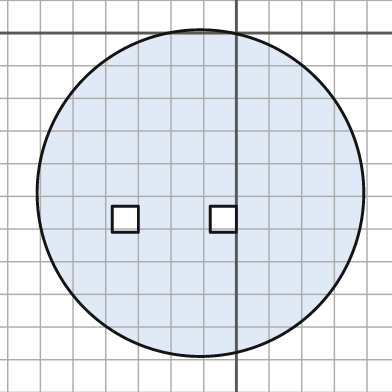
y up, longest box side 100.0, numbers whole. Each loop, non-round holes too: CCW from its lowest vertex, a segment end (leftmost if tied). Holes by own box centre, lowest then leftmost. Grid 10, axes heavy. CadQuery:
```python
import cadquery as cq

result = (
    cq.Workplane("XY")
    .moveTo(-11.0, -49.0)
    .circle(50.0)
    .moveTo(-38.0, -61.0)
    .lineTo(-30.0, -61.0)
    .lineTo(-30.0, -53.0)
    .lineTo(-38.0, -53.0)
    .close()
    .moveTo(-8.0, -61.0)
    .lineTo(0.0, -61.0)
    .lineTo(0.0, -53.0)
    .lineTo(-8.0, -53.0)
    .close()
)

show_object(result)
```